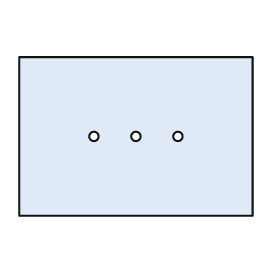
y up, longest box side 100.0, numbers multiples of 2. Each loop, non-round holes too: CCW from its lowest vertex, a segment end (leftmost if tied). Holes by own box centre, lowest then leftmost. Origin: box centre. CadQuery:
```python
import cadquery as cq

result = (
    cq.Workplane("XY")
    .moveTo(-50.0, -34.0)
    .lineTo(50.0, -34.0)
    .lineTo(50.0, 34.0)
    .lineTo(-50.0, 34.0)
    .close()
    .moveTo(-18.0, 0.0)
    .circle(2.0)
    .moveTo(0.0, 0.0)
    .circle(2.0)
    .moveTo(18.0, 0.0)
    .circle(2.0)
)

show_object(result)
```